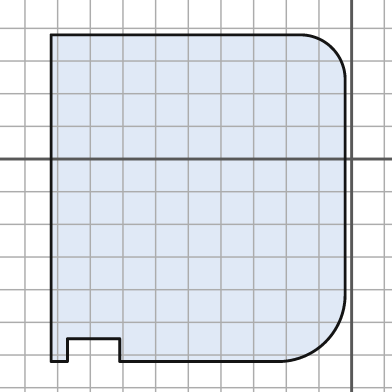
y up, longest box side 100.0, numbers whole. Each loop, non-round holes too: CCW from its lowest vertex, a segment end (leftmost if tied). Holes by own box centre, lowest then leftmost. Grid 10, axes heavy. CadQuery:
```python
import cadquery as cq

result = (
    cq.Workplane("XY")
    .moveTo(-92.0, -62.0)
    .lineTo(-87.0, -62.0)
    .lineTo(-87.0, -55.0)
    .lineTo(-71.0, -55.0)
    .lineTo(-71.0, -62.0)
    .lineTo(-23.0, -62.0)
    .threePointArc((-8.0, -56.0), (-2.0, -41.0))
    .lineTo(-2.0, 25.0)
    .threePointArc((-6.0, 34.0), (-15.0, 38.0))
    .lineTo(-92.0, 38.0)
    .close()
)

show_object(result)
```